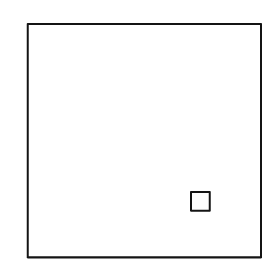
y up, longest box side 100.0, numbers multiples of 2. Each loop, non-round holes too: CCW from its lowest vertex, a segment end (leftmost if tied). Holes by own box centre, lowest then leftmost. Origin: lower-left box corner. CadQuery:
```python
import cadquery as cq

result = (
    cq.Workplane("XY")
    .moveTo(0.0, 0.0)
    .lineTo(100.0, 0.0)
    .lineTo(100.0, 100.0)
    .lineTo(0.0, 100.0)
    .close()
    .moveTo(70.0, 20.0)
    .lineTo(78.0, 20.0)
    .lineTo(78.0, 28.0)
    .lineTo(70.0, 28.0)
    .close()
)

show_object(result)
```